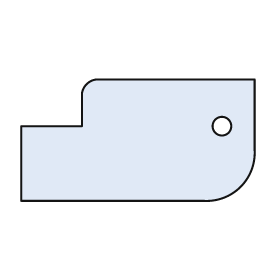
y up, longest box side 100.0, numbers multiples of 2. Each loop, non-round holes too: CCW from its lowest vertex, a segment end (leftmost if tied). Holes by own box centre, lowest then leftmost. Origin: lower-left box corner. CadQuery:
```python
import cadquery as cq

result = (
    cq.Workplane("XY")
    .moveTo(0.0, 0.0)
    .lineTo(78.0, 0.0)
    .threePointArc((94.0, 6.0), (100.0, 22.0))
    .lineTo(100.0, 52.0)
    .lineTo(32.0, 52.0)
    .threePointArc((28.0, 50.0), (26.0, 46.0))
    .lineTo(26.0, 32.0)
    .lineTo(0.0, 32.0)
    .close()
    .moveTo(86.0, 32.0)
    .circle(4.0)
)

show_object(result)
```